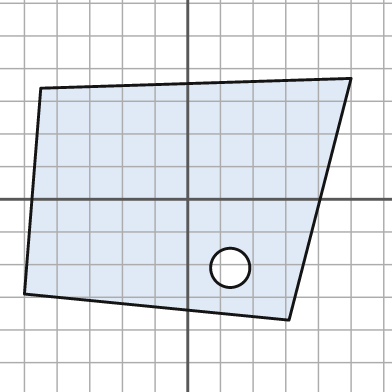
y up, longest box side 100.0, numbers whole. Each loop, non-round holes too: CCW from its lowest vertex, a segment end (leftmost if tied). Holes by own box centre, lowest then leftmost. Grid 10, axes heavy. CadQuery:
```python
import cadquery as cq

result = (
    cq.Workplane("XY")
    .moveTo(31.0, -37.0)
    .lineTo(50.0, 37.0)
    .lineTo(-45.0, 34.0)
    .lineTo(-50.0, -29.0)
    .close()
    .moveTo(13.0, -21.0)
    .circle(6.0)
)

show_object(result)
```